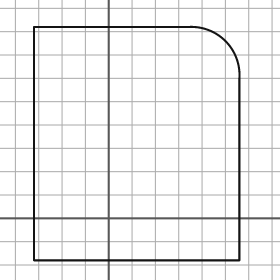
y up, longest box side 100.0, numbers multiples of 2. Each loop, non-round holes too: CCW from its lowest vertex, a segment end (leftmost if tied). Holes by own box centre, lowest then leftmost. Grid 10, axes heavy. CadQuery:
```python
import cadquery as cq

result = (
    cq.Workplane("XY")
    .moveTo(-32.0, -18.0)
    .lineTo(56.0, -18.0)
    .lineTo(56.0, 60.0)
    .threePointArc((50.0, 76.0), (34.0, 82.0))
    .lineTo(-32.0, 82.0)
    .close()
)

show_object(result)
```